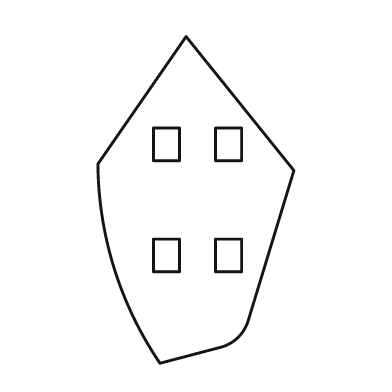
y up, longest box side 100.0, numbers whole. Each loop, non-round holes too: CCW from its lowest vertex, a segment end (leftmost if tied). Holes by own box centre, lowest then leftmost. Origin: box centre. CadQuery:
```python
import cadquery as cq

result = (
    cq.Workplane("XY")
    .moveTo(-11.0, -50.0)
    .lineTo(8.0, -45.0)
    .threePointArc((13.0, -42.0), (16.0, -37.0))
    .lineTo(30.0, 9.0)
    .lineTo(-3.0, 50.0)
    .lineTo(-30.0, 11.0)
    .threePointArc((-25.0, -21.0), (-11.0, -50.0))
    .close()
    .moveTo(-13.0, -22.0)
    .lineTo(-5.0, -22.0)
    .lineTo(-5.0, -12.0)
    .lineTo(-13.0, -12.0)
    .close()
    .moveTo(6.0, -22.0)
    .lineTo(14.0, -22.0)
    .lineTo(14.0, -12.0)
    .lineTo(6.0, -12.0)
    .close()
    .moveTo(-13.0, 12.0)
    .lineTo(-5.0, 12.0)
    .lineTo(-5.0, 22.0)
    .lineTo(-13.0, 22.0)
    .close()
    .moveTo(6.0, 12.0)
    .lineTo(14.0, 12.0)
    .lineTo(14.0, 22.0)
    .lineTo(6.0, 22.0)
    .close()
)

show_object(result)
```